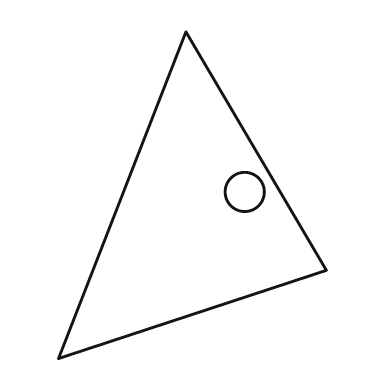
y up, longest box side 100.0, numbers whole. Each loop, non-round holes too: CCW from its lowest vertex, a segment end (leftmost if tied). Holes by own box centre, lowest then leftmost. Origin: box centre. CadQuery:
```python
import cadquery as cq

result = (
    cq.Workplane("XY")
    .moveTo(-41.0, -50.0)
    .lineTo(41.0, -23.0)
    .lineTo(-2.0, 50.0)
    .close()
    .moveTo(16.0, 1.0)
    .circle(6.0)
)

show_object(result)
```